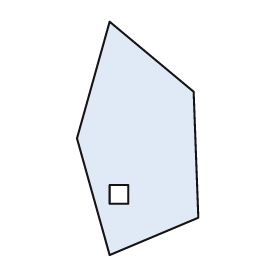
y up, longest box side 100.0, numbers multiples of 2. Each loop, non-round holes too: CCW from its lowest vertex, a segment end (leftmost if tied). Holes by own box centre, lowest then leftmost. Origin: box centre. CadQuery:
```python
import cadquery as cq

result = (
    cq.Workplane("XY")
    .moveTo(-12.0, -50.0)
    .lineTo(26.0, -34.0)
    .lineTo(24.0, 20.0)
    .lineTo(-12.0, 50.0)
    .lineTo(-26.0, 0.0)
    .close()
    .moveTo(-12.0, -28.0)
    .lineTo(-4.0, -28.0)
    .lineTo(-4.0, -20.0)
    .lineTo(-12.0, -20.0)
    .close()
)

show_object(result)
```